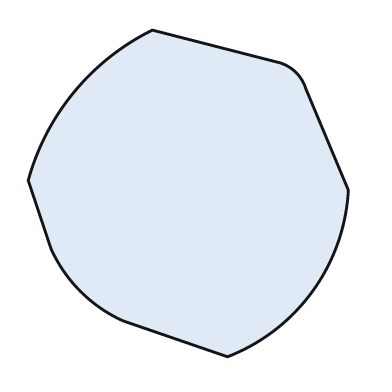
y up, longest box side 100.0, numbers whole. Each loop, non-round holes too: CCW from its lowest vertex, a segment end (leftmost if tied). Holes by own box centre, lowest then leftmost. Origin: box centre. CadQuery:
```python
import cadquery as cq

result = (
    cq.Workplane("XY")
    .moveTo(12.0, -50.0)
    .threePointArc((38.0, -30.0), (49.0, 1.0))
    .lineTo(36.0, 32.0)
    .threePointArc((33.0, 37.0), (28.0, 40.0))
    .lineTo(-11.0, 50.0)
    .threePointArc((-35.0, 31.0), (-49.0, 4.0))
    .lineTo(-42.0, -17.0)
    .threePointArc((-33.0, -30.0), (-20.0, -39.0))
    .close()
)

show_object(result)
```